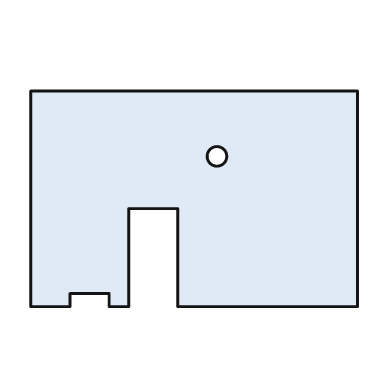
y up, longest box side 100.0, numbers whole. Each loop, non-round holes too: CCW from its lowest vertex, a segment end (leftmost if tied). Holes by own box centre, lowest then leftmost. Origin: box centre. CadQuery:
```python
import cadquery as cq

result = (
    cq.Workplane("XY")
    .moveTo(-50.0, -33.0)
    .lineTo(-38.0, -33.0)
    .lineTo(-38.0, -29.0)
    .lineTo(-26.0, -29.0)
    .lineTo(-26.0, -33.0)
    .lineTo(-20.0, -33.0)
    .lineTo(-20.0, -3.0)
    .lineTo(-5.0, -3.0)
    .lineTo(-5.0, -33.0)
    .lineTo(50.0, -33.0)
    .lineTo(50.0, 33.0)
    .lineTo(-50.0, 33.0)
    .close()
    .moveTo(7.0, 13.0)
    .circle(3.0)
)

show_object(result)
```